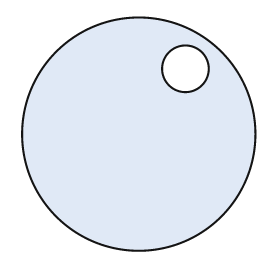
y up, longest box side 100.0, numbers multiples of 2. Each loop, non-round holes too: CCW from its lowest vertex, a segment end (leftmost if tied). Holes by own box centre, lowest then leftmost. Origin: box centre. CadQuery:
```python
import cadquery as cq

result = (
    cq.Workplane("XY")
    .moveTo(0.0, 0.0)
    .circle(50.0)
    .moveTo(20.0, 28.0)
    .circle(10.0)
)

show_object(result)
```